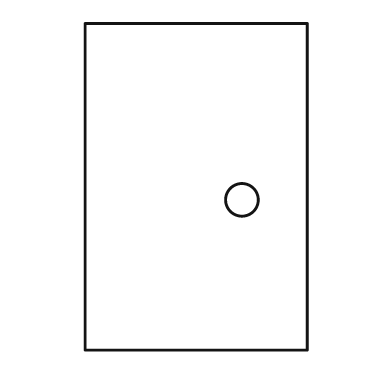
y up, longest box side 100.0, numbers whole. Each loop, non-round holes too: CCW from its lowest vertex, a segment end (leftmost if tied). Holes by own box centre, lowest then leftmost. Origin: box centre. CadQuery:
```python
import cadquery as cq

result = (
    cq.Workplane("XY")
    .moveTo(-34.0, -50.0)
    .lineTo(34.0, -50.0)
    .lineTo(34.0, 50.0)
    .lineTo(-34.0, 50.0)
    .close()
    .moveTo(14.0, -4.0)
    .circle(5.0)
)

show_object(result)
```